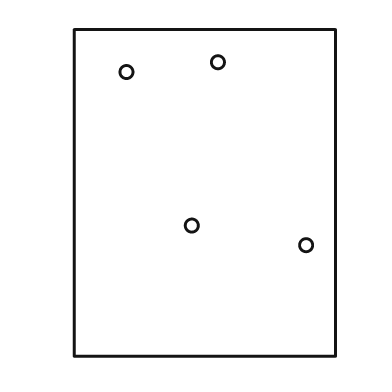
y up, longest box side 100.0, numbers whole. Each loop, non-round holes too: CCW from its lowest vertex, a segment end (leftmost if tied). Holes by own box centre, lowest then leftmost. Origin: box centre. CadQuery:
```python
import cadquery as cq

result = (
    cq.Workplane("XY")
    .moveTo(-40.0, -50.0)
    .lineTo(40.0, -50.0)
    .lineTo(40.0, 50.0)
    .lineTo(-40.0, 50.0)
    .close()
    .moveTo(31.0, -16.0)
    .circle(2.0)
    .moveTo(-4.0, -10.0)
    .circle(2.0)
    .moveTo(-24.0, 37.0)
    .circle(2.0)
    .moveTo(4.0, 40.0)
    .circle(2.0)
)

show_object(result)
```